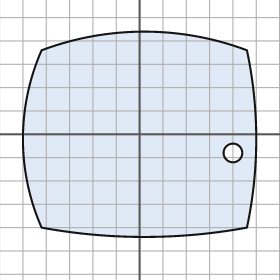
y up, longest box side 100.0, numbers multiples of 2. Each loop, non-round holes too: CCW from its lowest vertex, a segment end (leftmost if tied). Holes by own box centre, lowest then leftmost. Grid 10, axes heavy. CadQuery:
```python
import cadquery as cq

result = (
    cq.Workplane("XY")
    .moveTo(-42.0, -40.0)
    .threePointArc((2.0, -44.0), (46.0, -40.0))
    .threePointArc((50.0, -2.0), (46.0, 36.0))
    .threePointArc((2.0, 44.0), (-42.0, 36.0))
    .threePointArc((-50.0, -2.0), (-42.0, -40.0))
    .close()
    .moveTo(40.0, -8.0)
    .circle(4.0)
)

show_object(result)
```